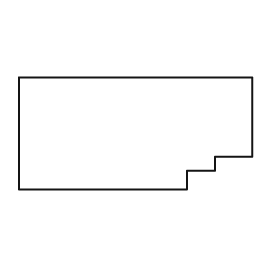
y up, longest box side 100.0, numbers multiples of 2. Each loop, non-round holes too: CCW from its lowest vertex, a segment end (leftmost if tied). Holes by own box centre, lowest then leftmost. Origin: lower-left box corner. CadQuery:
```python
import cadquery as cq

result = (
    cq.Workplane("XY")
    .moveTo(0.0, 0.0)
    .lineTo(72.0, 0.0)
    .lineTo(72.0, 8.0)
    .lineTo(84.0, 8.0)
    .lineTo(84.0, 14.0)
    .lineTo(100.0, 14.0)
    .lineTo(100.0, 48.0)
    .lineTo(0.0, 48.0)
    .close()
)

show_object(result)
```